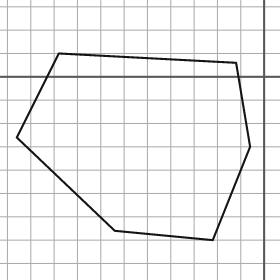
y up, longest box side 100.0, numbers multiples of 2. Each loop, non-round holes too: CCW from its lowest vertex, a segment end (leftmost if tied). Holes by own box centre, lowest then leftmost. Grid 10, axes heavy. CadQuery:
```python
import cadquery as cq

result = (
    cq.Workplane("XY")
    .moveTo(-22.0, -70.0)
    .lineTo(-6.0, -30.0)
    .lineTo(-12.0, 6.0)
    .lineTo(-88.0, 10.0)
    .lineTo(-106.0, -26.0)
    .lineTo(-64.0, -66.0)
    .close()
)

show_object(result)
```